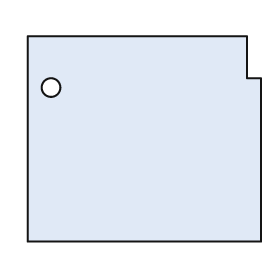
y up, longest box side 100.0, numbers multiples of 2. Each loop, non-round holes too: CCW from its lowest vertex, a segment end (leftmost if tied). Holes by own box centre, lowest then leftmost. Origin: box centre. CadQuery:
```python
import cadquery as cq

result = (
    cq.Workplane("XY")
    .moveTo(-50.0, -44.0)
    .lineTo(50.0, -44.0)
    .lineTo(50.0, 26.0)
    .lineTo(44.0, 26.0)
    .lineTo(44.0, 44.0)
    .lineTo(-50.0, 44.0)
    .close()
    .moveTo(-40.0, 22.0)
    .circle(4.0)
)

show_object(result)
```